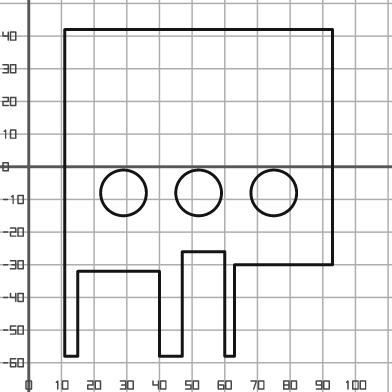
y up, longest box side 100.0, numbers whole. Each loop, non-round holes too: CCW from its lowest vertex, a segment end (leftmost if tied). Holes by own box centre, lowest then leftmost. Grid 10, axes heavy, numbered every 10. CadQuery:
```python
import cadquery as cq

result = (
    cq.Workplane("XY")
    .moveTo(11.0, -58.0)
    .lineTo(15.0, -58.0)
    .lineTo(15.0, -32.0)
    .lineTo(40.0, -32.0)
    .lineTo(40.0, -58.0)
    .lineTo(47.0, -58.0)
    .lineTo(47.0, -26.0)
    .lineTo(60.0, -26.0)
    .lineTo(60.0, -58.0)
    .lineTo(63.0, -58.0)
    .lineTo(63.0, -30.0)
    .lineTo(93.0, -30.0)
    .lineTo(93.0, 42.0)
    .lineTo(11.0, 42.0)
    .close()
    .moveTo(29.0, -8.0)
    .circle(7.0)
    .moveTo(52.0, -8.0)
    .circle(7.0)
    .moveTo(75.0, -8.0)
    .circle(7.0)
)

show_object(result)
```